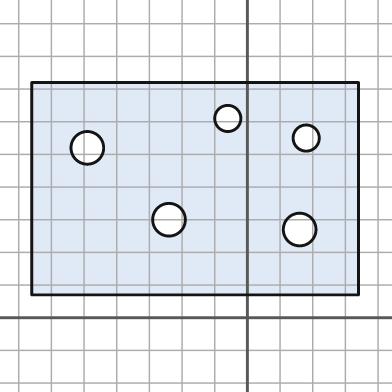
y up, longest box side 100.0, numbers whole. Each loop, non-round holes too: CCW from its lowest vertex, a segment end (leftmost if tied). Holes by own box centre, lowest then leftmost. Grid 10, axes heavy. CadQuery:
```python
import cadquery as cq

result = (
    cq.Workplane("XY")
    .moveTo(-66.0, 7.0)
    .lineTo(34.0, 7.0)
    .lineTo(34.0, 72.0)
    .lineTo(-66.0, 72.0)
    .close()
    .moveTo(16.0, 27.0)
    .circle(5.0)
    .moveTo(-24.0, 30.0)
    .circle(5.0)
    .moveTo(-49.0, 52.0)
    .circle(5.0)
    .moveTo(18.0, 55.0)
    .circle(4.0)
    .moveTo(-6.0, 61.0)
    .circle(4.0)
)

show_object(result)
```